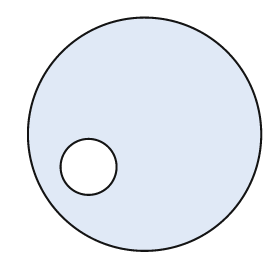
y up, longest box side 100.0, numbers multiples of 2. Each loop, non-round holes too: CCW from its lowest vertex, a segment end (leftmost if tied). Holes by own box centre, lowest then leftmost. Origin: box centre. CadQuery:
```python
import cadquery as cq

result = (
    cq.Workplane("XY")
    .moveTo(0.0, 0.0)
    .circle(50.0)
    .moveTo(-24.0, -14.0)
    .circle(12.0)
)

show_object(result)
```